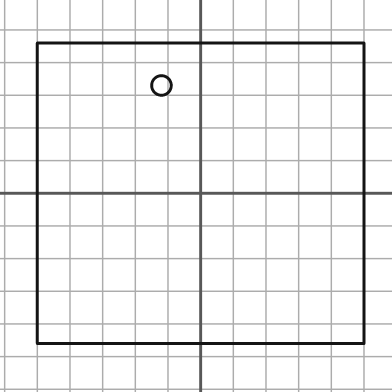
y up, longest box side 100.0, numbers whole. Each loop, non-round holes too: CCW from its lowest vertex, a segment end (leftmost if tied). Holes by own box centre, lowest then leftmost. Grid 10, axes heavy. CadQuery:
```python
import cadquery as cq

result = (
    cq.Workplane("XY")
    .moveTo(-50.0, -46.0)
    .lineTo(50.0, -46.0)
    .lineTo(50.0, 46.0)
    .lineTo(-50.0, 46.0)
    .close()
    .moveTo(-12.0, 33.0)
    .circle(3.0)
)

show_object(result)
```